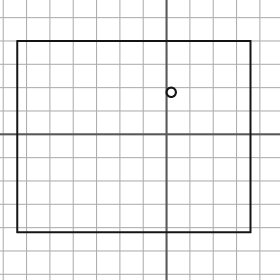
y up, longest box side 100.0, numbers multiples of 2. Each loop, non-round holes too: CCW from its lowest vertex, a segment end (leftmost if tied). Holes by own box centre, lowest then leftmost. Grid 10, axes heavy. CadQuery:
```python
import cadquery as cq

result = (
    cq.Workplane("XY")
    .moveTo(-64.0, -42.0)
    .lineTo(36.0, -42.0)
    .lineTo(36.0, 40.0)
    .lineTo(-64.0, 40.0)
    .close()
    .moveTo(2.0, 18.0)
    .circle(2.0)
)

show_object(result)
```